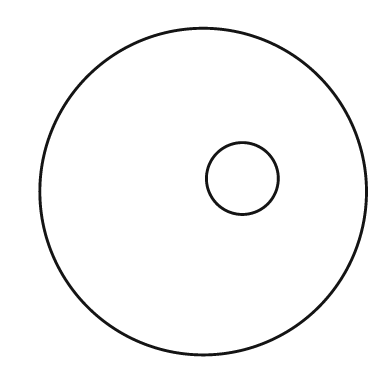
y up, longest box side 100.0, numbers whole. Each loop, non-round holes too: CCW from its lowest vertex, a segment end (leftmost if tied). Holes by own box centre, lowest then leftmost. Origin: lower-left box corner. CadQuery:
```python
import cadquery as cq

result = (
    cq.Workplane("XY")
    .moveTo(50.0, 50.0)
    .circle(50.0)
    .moveTo(62.0, 54.0)
    .circle(11.0)
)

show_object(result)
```